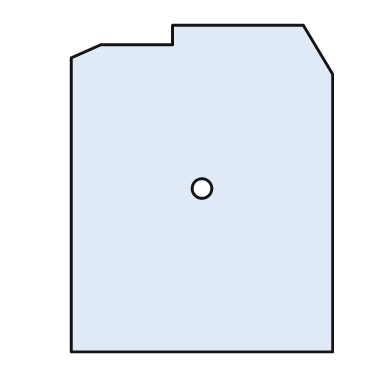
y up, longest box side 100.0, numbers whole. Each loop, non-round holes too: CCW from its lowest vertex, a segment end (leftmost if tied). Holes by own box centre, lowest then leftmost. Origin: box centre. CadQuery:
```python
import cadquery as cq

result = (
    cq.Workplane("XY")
    .moveTo(-40.0, -50.0)
    .lineTo(40.0, -50.0)
    .lineTo(40.0, 35.0)
    .lineTo(31.0, 50.0)
    .lineTo(-9.0, 50.0)
    .lineTo(-9.0, 44.0)
    .lineTo(-31.0, 44.0)
    .lineTo(-40.0, 40.0)
    .close()
    .moveTo(0.0, 0.0)
    .circle(3.0)
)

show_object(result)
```